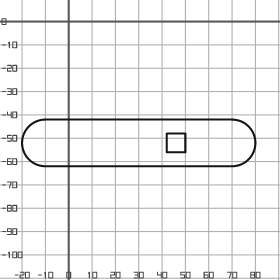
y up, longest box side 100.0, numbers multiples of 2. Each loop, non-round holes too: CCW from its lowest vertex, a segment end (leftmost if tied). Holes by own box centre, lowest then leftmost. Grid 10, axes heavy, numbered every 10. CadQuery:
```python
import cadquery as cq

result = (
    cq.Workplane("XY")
    .moveTo(-10.0, -62.0)
    .lineTo(70.0, -62.0)
    .threePointArc((80.0, -52.0), (70.0, -42.0))
    .lineTo(-10.0, -42.0)
    .threePointArc((-20.0, -52.0), (-10.0, -62.0))
    .close()
    .moveTo(42.0, -56.0)
    .lineTo(50.0, -56.0)
    .lineTo(50.0, -48.0)
    .lineTo(42.0, -48.0)
    .close()
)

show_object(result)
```